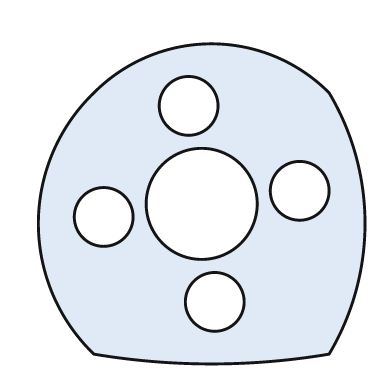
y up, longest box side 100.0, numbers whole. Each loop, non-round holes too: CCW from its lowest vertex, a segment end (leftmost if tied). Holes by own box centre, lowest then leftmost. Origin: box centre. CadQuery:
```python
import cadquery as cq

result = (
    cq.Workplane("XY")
    .moveTo(-33.0, -46.0)
    .threePointArc((3.0, -49.0), (39.0, -46.0))
    .threePointArc((50.0, -6.0), (39.0, 34.0))
    .threePointArc((3.0, 49.0), (-33.0, 34.0))
    .threePointArc((-50.0, -6.0), (-33.0, -46.0))
    .close()
    .moveTo(4.0, -30.0)
    .circle(9.0)
    .moveTo(-30.0, -4.0)
    .circle(9.0)
    .moveTo(0.0, 0.0)
    .circle(17.0)
    .moveTo(30.0, 4.0)
    .circle(9.0)
    .moveTo(-4.0, 30.0)
    .circle(9.0)
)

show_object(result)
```